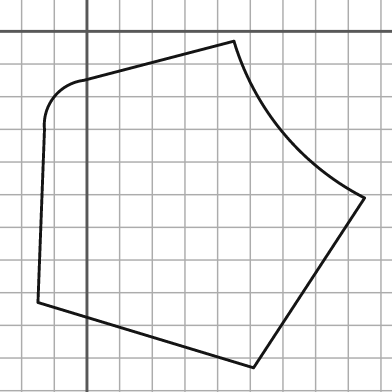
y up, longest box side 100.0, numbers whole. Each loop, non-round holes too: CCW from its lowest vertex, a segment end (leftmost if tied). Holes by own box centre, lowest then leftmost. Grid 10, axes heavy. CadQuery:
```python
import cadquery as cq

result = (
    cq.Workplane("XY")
    .moveTo(51.0, -103.0)
    .lineTo(85.0, -51.0)
    .threePointArc((60.0, -31.0), (45.0, -3.0))
    .lineTo(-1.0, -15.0)
    .threePointArc((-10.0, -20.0), (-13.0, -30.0))
    .lineTo(-15.0, -83.0)
    .close()
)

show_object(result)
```